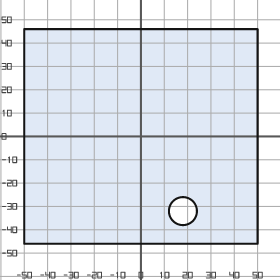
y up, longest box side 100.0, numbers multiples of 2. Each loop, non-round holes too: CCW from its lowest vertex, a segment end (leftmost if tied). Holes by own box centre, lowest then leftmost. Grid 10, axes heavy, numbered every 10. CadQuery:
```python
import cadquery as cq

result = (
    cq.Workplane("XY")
    .moveTo(-50.0, -46.0)
    .lineTo(50.0, -46.0)
    .lineTo(50.0, 46.0)
    .lineTo(-50.0, 46.0)
    .close()
    .moveTo(18.0, -32.0)
    .circle(6.0)
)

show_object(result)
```